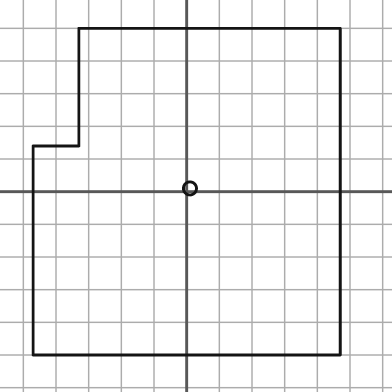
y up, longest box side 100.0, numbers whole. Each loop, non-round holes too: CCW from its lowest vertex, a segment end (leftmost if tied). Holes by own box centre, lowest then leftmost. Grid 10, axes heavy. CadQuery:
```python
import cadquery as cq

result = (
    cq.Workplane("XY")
    .moveTo(-47.0, -50.0)
    .lineTo(47.0, -50.0)
    .lineTo(47.0, 50.0)
    .lineTo(-33.0, 50.0)
    .lineTo(-33.0, 14.0)
    .lineTo(-47.0, 14.0)
    .close()
    .moveTo(1.0, 1.0)
    .circle(2.0)
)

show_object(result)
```